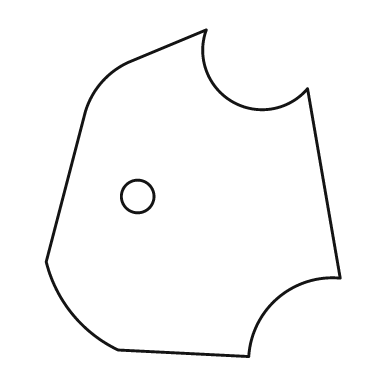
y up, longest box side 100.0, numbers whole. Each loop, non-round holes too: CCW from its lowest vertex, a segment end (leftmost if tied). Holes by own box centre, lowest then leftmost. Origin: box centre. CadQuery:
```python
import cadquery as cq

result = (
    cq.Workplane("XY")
    .moveTo(17.0, -50.0)
    .threePointArc((26.0, -32.0), (45.0, -26.0))
    .lineTo(35.0, 32.0)
    .threePointArc((12.0, 28.0), (4.0, 50.0))
    .lineTo(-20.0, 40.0)
    .threePointArc((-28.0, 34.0), (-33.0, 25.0))
    .lineTo(-45.0, -21.0)
    .threePointArc((-37.0, -37.0), (-23.0, -48.0))
    .close()
    .moveTo(-17.0, -1.0)
    .circle(5.0)
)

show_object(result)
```